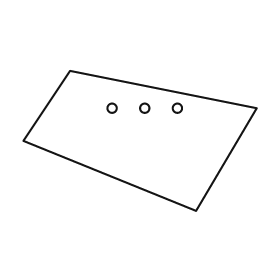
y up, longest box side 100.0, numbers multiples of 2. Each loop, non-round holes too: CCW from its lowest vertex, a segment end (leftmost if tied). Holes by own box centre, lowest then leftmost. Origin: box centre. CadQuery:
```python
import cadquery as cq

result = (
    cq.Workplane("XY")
    .moveTo(24.0, -30.0)
    .lineTo(50.0, 14.0)
    .lineTo(-30.0, 30.0)
    .lineTo(-50.0, 0.0)
    .close()
    .moveTo(-12.0, 14.0)
    .circle(2.0)
    .moveTo(2.0, 14.0)
    .circle(2.0)
    .moveTo(16.0, 14.0)
    .circle(2.0)
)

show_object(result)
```